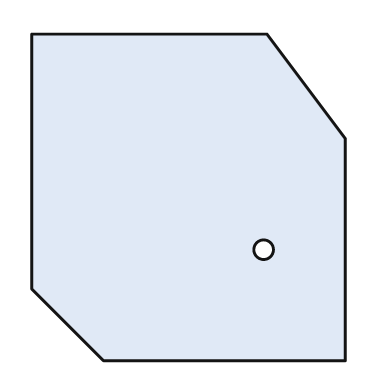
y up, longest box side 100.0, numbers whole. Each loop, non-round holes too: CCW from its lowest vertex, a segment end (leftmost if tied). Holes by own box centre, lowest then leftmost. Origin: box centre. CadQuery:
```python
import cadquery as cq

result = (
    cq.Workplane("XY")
    .moveTo(-26.0, -50.0)
    .lineTo(48.0, -50.0)
    .lineTo(48.0, 18.0)
    .lineTo(24.0, 50.0)
    .lineTo(-48.0, 50.0)
    .lineTo(-48.0, -28.0)
    .close()
    .moveTo(23.0, -16.0)
    .circle(3.0)
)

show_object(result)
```